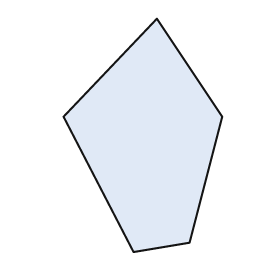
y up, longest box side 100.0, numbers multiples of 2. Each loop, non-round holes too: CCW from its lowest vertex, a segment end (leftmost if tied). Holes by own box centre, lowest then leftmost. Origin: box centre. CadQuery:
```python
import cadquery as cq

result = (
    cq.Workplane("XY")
    .moveTo(-4.0, -50.0)
    .lineTo(20.0, -46.0)
    .lineTo(34.0, 8.0)
    .lineTo(6.0, 50.0)
    .lineTo(-34.0, 8.0)
    .close()
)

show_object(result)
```